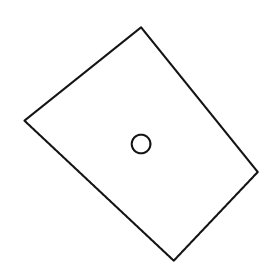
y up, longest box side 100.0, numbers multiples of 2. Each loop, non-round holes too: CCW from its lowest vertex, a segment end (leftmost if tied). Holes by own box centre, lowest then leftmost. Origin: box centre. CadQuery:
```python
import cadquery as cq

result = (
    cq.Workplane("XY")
    .moveTo(14.0, -50.0)
    .lineTo(50.0, -12.0)
    .lineTo(0.0, 50.0)
    .lineTo(-50.0, 10.0)
    .close()
    .moveTo(0.0, 0.0)
    .circle(4.0)
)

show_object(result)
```